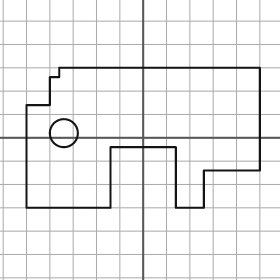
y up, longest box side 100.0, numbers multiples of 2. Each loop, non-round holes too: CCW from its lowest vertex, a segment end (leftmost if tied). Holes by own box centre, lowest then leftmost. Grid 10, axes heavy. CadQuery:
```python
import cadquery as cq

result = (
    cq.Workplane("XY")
    .moveTo(-50.0, -30.0)
    .lineTo(-14.0, -30.0)
    .lineTo(-14.0, -4.0)
    .lineTo(14.0, -4.0)
    .lineTo(14.0, -30.0)
    .lineTo(26.0, -30.0)
    .lineTo(26.0, -14.0)
    .lineTo(50.0, -14.0)
    .lineTo(50.0, 30.0)
    .lineTo(-36.0, 30.0)
    .lineTo(-36.0, 26.0)
    .lineTo(-40.0, 26.0)
    .lineTo(-40.0, 14.0)
    .lineTo(-50.0, 14.0)
    .close()
    .moveTo(-34.0, 2.0)
    .circle(6.0)
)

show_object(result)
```